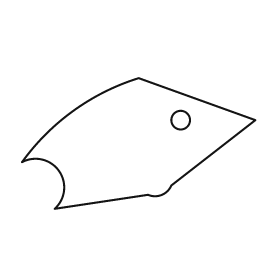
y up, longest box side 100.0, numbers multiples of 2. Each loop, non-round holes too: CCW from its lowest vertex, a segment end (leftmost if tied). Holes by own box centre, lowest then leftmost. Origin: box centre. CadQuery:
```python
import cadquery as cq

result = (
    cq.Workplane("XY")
    .moveTo(-36.0, -28.0)
    .lineTo(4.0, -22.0)
    .threePointArc((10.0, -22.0), (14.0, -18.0))
    .lineTo(50.0, 10.0)
    .lineTo(0.0, 28.0)
    .threePointArc((-28.0, 14.0), (-50.0, -8.0))
    .threePointArc((-34.0, -12.0), (-36.0, -28.0))
    .close()
    .moveTo(18.0, 10.0)
    .circle(4.0)
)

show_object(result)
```